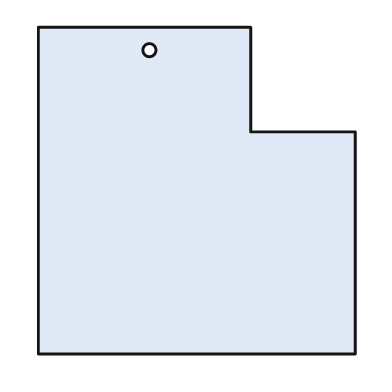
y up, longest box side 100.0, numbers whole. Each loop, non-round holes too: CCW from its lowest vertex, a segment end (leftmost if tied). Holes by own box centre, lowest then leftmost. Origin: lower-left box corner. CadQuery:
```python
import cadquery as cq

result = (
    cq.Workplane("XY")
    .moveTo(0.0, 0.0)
    .lineTo(97.0, 0.0)
    .lineTo(97.0, 68.0)
    .lineTo(65.0, 68.0)
    .lineTo(65.0, 100.0)
    .lineTo(0.0, 100.0)
    .close()
    .moveTo(34.0, 93.0)
    .circle(2.0)
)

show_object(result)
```